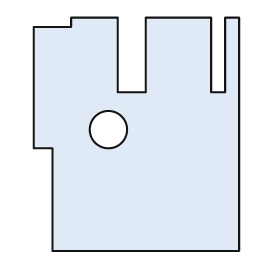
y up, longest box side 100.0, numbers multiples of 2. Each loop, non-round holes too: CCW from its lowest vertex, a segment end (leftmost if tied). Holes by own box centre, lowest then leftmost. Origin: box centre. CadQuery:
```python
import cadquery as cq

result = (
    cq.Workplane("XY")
    .moveTo(-36.0, -50.0)
    .lineTo(44.0, -50.0)
    .lineTo(44.0, 50.0)
    .lineTo(38.0, 50.0)
    .lineTo(38.0, 18.0)
    .lineTo(32.0, 18.0)
    .lineTo(32.0, 50.0)
    .lineTo(4.0, 50.0)
    .lineTo(4.0, 18.0)
    .lineTo(-8.0, 18.0)
    .lineTo(-8.0, 50.0)
    .lineTo(-28.0, 50.0)
    .lineTo(-28.0, 46.0)
    .lineTo(-44.0, 46.0)
    .lineTo(-44.0, -6.0)
    .lineTo(-36.0, -6.0)
    .close()
    .moveTo(-12.0, 2.0)
    .circle(8.0)
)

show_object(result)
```